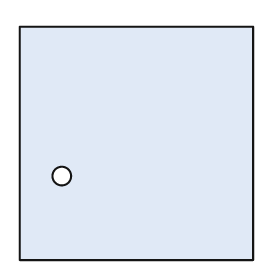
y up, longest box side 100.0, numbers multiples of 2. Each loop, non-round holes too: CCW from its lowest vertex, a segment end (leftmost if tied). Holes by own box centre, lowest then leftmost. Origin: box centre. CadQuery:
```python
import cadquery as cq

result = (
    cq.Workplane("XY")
    .moveTo(-50.0, -50.0)
    .lineTo(50.0, -50.0)
    .lineTo(50.0, 50.0)
    .lineTo(-50.0, 50.0)
    .close()
    .moveTo(-32.0, -14.0)
    .circle(4.0)
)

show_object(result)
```